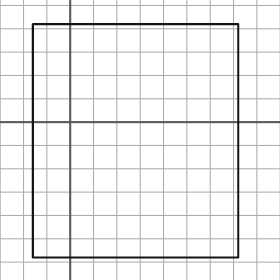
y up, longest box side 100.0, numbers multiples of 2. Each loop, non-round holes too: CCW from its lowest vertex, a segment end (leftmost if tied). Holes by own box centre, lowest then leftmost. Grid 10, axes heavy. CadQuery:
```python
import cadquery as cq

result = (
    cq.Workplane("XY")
    .moveTo(-16.0, -58.0)
    .lineTo(72.0, -58.0)
    .lineTo(72.0, 42.0)
    .lineTo(-16.0, 42.0)
    .close()
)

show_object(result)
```